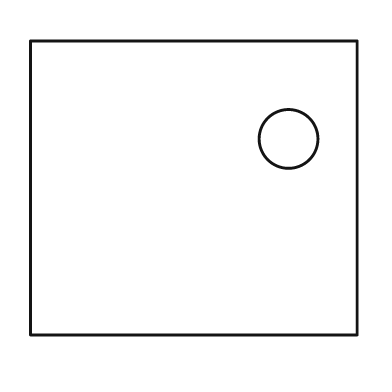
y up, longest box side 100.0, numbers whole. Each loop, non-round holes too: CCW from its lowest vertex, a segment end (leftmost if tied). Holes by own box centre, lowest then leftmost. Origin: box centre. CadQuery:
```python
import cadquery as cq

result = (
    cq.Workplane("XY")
    .moveTo(-50.0, -45.0)
    .lineTo(50.0, -45.0)
    .lineTo(50.0, 45.0)
    .lineTo(-50.0, 45.0)
    .close()
    .moveTo(29.0, 15.0)
    .circle(9.0)
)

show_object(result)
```